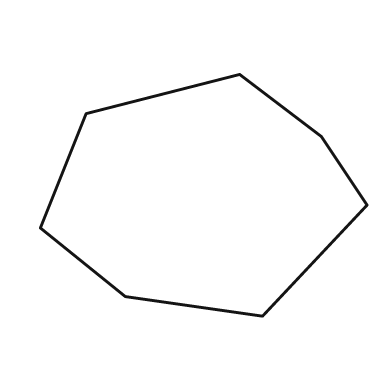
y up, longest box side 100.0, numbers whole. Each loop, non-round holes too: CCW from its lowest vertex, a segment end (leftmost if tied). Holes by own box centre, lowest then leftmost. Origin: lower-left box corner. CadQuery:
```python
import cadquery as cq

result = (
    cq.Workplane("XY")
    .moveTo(68.0, 0.0)
    .lineTo(100.0, 34.0)
    .lineTo(86.0, 55.0)
    .lineTo(61.0, 74.0)
    .lineTo(14.0, 62.0)
    .lineTo(0.0, 27.0)
    .lineTo(26.0, 6.0)
    .close()
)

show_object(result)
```